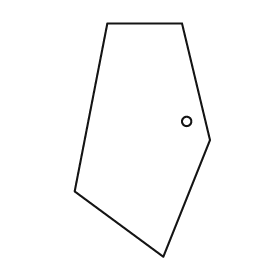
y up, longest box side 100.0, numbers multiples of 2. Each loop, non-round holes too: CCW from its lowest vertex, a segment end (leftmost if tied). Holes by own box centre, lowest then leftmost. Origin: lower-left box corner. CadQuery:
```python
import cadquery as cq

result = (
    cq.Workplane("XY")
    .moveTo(38.0, 0.0)
    .lineTo(58.0, 50.0)
    .lineTo(46.0, 100.0)
    .lineTo(14.0, 100.0)
    .lineTo(0.0, 28.0)
    .close()
    .moveTo(48.0, 58.0)
    .circle(2.0)
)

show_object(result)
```